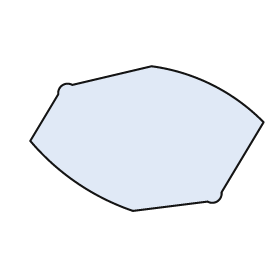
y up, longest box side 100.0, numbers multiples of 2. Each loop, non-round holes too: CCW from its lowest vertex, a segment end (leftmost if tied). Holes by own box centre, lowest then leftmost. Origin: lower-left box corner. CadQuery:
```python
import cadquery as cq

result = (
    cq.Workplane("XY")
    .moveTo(44.0, 0.0)
    .lineTo(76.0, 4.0)
    .threePointArc((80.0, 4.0), (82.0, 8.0))
    .lineTo(100.0, 38.0)
    .threePointArc((78.0, 54.0), (52.0, 62.0))
    .lineTo(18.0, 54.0)
    .threePointArc((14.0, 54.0), (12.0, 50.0))
    .lineTo(0.0, 30.0)
    .threePointArc((20.0, 12.0), (44.0, 0.0))
    .close()
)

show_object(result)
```